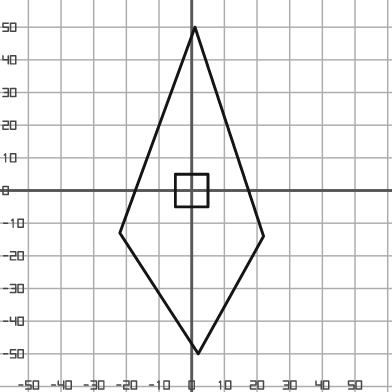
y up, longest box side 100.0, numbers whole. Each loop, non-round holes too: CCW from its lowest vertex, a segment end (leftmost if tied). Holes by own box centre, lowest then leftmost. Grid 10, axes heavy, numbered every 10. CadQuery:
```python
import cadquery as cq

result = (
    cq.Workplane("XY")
    .moveTo(2.0, -50.0)
    .lineTo(22.0, -14.0)
    .lineTo(1.0, 50.0)
    .lineTo(-22.0, -13.0)
    .close()
    .moveTo(-5.0, -5.0)
    .lineTo(5.0, -5.0)
    .lineTo(5.0, 5.0)
    .lineTo(-5.0, 5.0)
    .close()
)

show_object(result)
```